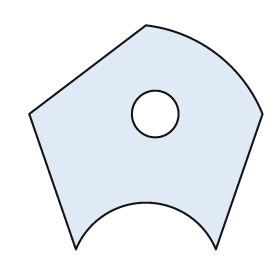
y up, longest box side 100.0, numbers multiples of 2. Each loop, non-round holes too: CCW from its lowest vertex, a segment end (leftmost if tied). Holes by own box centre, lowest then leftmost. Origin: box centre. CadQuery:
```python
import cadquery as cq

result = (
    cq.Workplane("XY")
    .moveTo(-30.0, -48.0)
    .threePointArc((0.0, -28.0), (30.0, -48.0))
    .lineTo(50.0, 10.0)
    .threePointArc((30.0, 36.0), (0.0, 48.0))
    .lineTo(-50.0, 10.0)
    .close()
    .moveTo(4.0, 10.0)
    .circle(10.0)
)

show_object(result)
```